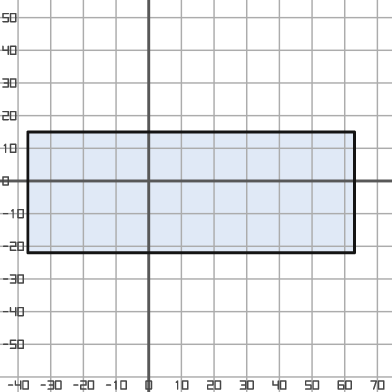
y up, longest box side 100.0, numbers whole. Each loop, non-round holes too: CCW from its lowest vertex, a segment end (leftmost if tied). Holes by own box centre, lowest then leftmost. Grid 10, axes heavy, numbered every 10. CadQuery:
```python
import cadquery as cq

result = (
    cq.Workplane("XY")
    .moveTo(-37.0, -22.0)
    .lineTo(63.0, -22.0)
    .lineTo(63.0, 15.0)
    .lineTo(-37.0, 15.0)
    .close()
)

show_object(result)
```